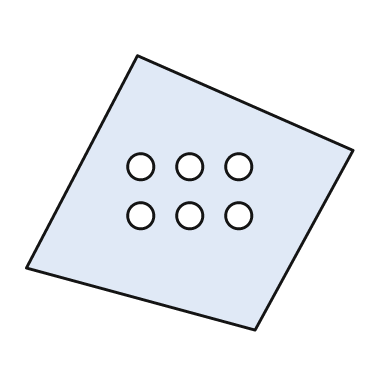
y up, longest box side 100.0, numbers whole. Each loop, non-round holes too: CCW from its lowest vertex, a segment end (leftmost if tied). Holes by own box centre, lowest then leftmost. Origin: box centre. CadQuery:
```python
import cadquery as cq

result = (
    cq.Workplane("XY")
    .moveTo(20.0, -42.0)
    .lineTo(50.0, 13.0)
    .lineTo(-16.0, 42.0)
    .lineTo(-50.0, -23.0)
    .close()
    .moveTo(-15.0, -7.0)
    .circle(4.0)
    .moveTo(0.0, -7.0)
    .circle(4.0)
    .moveTo(15.0, -7.0)
    .circle(4.0)
    .moveTo(-15.0, 8.0)
    .circle(4.0)
    .moveTo(0.0, 8.0)
    .circle(4.0)
    .moveTo(15.0, 8.0)
    .circle(4.0)
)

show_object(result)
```